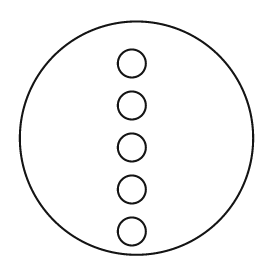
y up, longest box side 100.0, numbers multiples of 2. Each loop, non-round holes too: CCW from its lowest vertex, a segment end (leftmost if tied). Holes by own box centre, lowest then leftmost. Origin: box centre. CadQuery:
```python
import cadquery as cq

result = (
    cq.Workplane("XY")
    .moveTo(0.0, 0.0)
    .circle(50.0)
    .moveTo(-2.0, -40.0)
    .circle(6.0)
    .moveTo(-2.0, -22.0)
    .circle(6.0)
    .moveTo(-2.0, -4.0)
    .circle(6.0)
    .moveTo(-2.0, 14.0)
    .circle(6.0)
    .moveTo(-2.0, 32.0)
    .circle(6.0)
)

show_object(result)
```